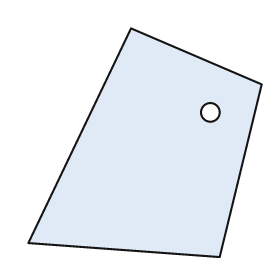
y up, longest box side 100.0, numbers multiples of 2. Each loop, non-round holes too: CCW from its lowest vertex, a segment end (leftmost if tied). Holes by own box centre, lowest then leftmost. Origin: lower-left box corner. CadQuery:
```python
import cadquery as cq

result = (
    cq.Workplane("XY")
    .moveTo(82.0, 0.0)
    .lineTo(100.0, 74.0)
    .lineTo(44.0, 98.0)
    .lineTo(0.0, 6.0)
    .close()
    .moveTo(78.0, 62.0)
    .circle(4.0)
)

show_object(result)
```